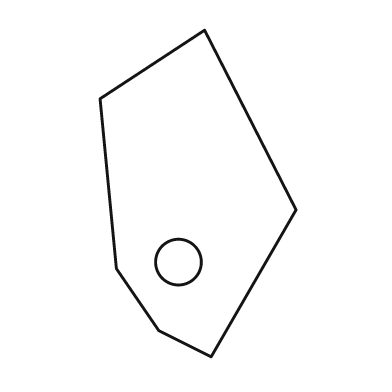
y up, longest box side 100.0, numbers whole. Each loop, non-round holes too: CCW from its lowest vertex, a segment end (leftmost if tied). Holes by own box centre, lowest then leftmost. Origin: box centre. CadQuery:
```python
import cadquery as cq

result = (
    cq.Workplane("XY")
    .moveTo(4.0, -50.0)
    .lineTo(30.0, -5.0)
    .lineTo(2.0, 50.0)
    .lineTo(-30.0, 29.0)
    .lineTo(-25.0, -23.0)
    .lineTo(-12.0, -42.0)
    .close()
    .moveTo(-6.0, -21.0)
    .circle(7.0)
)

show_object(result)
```